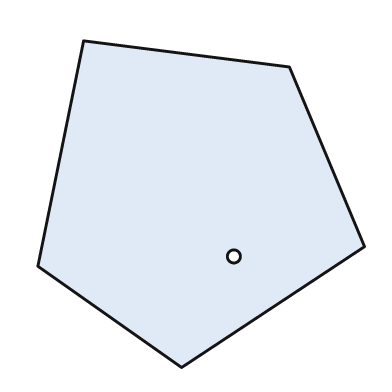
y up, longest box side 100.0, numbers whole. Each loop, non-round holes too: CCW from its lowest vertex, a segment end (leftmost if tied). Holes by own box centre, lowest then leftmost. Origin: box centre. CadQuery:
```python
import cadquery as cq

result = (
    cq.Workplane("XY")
    .moveTo(-6.0, -50.0)
    .lineTo(50.0, -13.0)
    .lineTo(27.0, 42.0)
    .lineTo(-36.0, 50.0)
    .lineTo(-50.0, -19.0)
    .close()
    .moveTo(10.0, -16.0)
    .circle(2.0)
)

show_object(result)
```